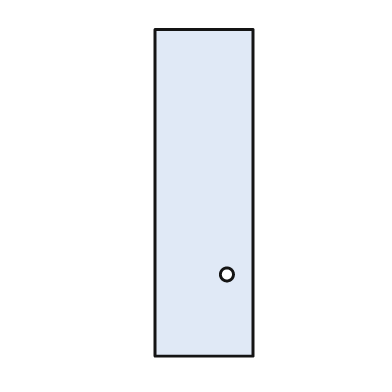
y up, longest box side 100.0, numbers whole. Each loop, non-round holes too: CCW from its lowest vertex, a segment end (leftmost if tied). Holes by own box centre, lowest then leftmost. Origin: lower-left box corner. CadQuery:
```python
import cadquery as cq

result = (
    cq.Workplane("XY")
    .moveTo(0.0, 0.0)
    .lineTo(30.0, 0.0)
    .lineTo(30.0, 100.0)
    .lineTo(0.0, 100.0)
    .close()
    .moveTo(22.0, 25.0)
    .circle(2.0)
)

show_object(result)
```